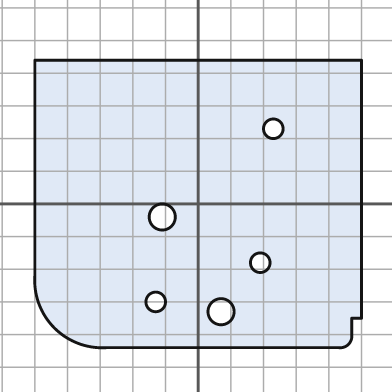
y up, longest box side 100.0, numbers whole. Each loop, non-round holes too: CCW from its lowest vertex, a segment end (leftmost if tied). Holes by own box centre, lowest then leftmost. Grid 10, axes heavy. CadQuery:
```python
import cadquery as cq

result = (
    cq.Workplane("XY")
    .moveTo(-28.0, -44.0)
    .lineTo(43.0, -44.0)
    .threePointArc((46.0, -43.0), (47.0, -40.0))
    .lineTo(47.0, -35.0)
    .lineTo(50.0, -35.0)
    .lineTo(50.0, 44.0)
    .lineTo(-50.0, 44.0)
    .lineTo(-50.0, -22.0)
    .threePointArc((-44.0, -38.0), (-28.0, -44.0))
    .close()
    .moveTo(7.0, -33.0)
    .circle(4.0)
    .moveTo(-13.0, -30.0)
    .circle(3.0)
    .moveTo(19.0, -18.0)
    .circle(3.0)
    .moveTo(-11.0, -4.0)
    .circle(4.0)
    .moveTo(23.0, 23.0)
    .circle(3.0)
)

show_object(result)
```